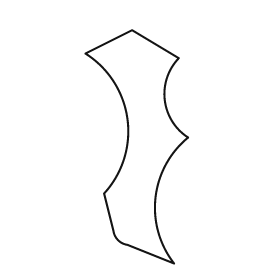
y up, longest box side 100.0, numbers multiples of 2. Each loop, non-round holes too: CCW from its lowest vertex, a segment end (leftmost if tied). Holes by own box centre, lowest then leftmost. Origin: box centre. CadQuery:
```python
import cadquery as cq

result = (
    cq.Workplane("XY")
    .moveTo(16.0, -50.0)
    .threePointArc((8.0, -22.0), (22.0, 4.0))
    .threePointArc((12.0, 20.0), (18.0, 38.0))
    .lineTo(-2.0, 50.0)
    .lineTo(-22.0, 40.0)
    .threePointArc((-4.0, 12.0), (-14.0, -20.0))
    .lineTo(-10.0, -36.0)
    .threePointArc((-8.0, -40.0), (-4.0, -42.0))
    .close()
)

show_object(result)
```